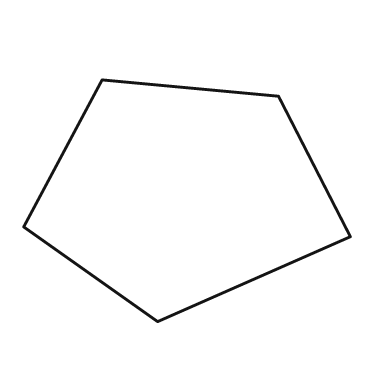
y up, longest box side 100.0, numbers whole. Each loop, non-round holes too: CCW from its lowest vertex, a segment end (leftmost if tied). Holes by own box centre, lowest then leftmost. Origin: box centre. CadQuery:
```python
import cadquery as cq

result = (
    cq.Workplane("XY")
    .moveTo(-9.0, -37.0)
    .lineTo(50.0, -11.0)
    .lineTo(28.0, 32.0)
    .lineTo(-26.0, 37.0)
    .lineTo(-50.0, -8.0)
    .close()
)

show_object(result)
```